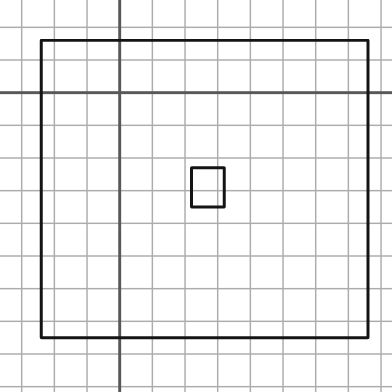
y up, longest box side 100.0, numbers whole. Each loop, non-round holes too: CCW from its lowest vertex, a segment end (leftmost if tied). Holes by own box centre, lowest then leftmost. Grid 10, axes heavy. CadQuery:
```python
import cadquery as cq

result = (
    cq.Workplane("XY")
    .moveTo(-24.0, -75.0)
    .lineTo(76.0, -75.0)
    .lineTo(76.0, 16.0)
    .lineTo(-24.0, 16.0)
    .close()
    .moveTo(22.0, -35.0)
    .lineTo(32.0, -35.0)
    .lineTo(32.0, -23.0)
    .lineTo(22.0, -23.0)
    .close()
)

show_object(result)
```